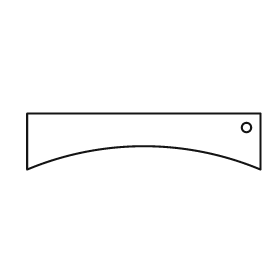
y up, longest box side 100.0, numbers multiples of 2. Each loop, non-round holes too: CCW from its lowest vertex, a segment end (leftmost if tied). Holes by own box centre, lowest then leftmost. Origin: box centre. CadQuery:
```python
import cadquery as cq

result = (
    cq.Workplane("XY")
    .moveTo(-50.0, -12.0)
    .threePointArc((0.0, -2.0), (50.0, -12.0))
    .lineTo(50.0, 12.0)
    .lineTo(-50.0, 12.0)
    .close()
    .moveTo(44.0, 6.0)
    .circle(2.0)
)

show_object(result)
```